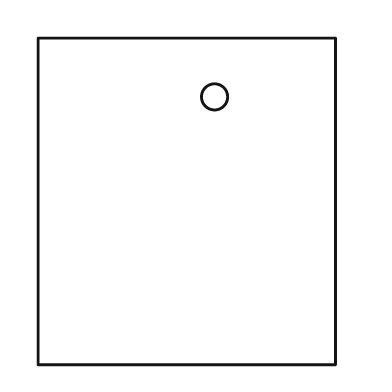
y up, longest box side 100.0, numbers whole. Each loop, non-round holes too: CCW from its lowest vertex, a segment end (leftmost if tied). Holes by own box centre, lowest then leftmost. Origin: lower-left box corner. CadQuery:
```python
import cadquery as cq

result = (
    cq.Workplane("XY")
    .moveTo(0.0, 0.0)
    .lineTo(91.0, 0.0)
    .lineTo(91.0, 100.0)
    .lineTo(0.0, 100.0)
    .close()
    .moveTo(54.0, 82.0)
    .circle(4.0)
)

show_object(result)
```